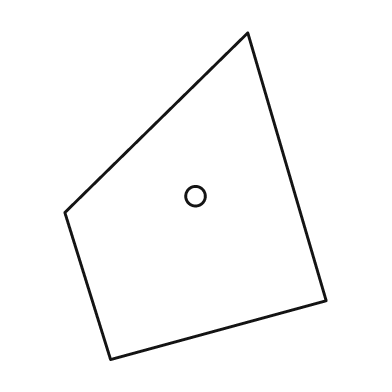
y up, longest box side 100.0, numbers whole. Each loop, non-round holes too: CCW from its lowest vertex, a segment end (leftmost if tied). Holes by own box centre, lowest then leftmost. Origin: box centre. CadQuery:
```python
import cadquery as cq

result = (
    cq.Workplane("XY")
    .moveTo(-26.0, -50.0)
    .lineTo(40.0, -32.0)
    .lineTo(16.0, 50.0)
    .lineTo(-40.0, -5.0)
    .close()
    .moveTo(0.0, 0.0)
    .circle(3.0)
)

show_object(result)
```